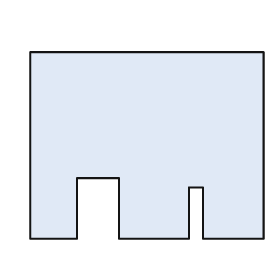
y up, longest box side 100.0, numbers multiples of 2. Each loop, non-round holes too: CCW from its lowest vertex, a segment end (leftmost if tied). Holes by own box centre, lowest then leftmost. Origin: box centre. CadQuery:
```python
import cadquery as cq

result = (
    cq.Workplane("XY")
    .moveTo(-50.0, -40.0)
    .lineTo(-30.0, -40.0)
    .lineTo(-30.0, -14.0)
    .lineTo(-12.0, -14.0)
    .lineTo(-12.0, -40.0)
    .lineTo(18.0, -40.0)
    .lineTo(18.0, -18.0)
    .lineTo(24.0, -18.0)
    .lineTo(24.0, -40.0)
    .lineTo(50.0, -40.0)
    .lineTo(50.0, 40.0)
    .lineTo(-50.0, 40.0)
    .close()
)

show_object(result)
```